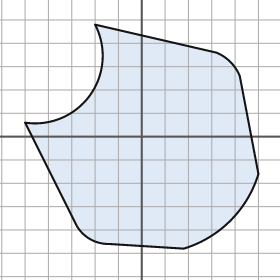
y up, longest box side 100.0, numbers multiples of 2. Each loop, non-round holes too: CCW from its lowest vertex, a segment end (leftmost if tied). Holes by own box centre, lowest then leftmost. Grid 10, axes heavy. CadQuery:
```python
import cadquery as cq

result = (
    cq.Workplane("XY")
    .moveTo(18.0, -48.0)
    .threePointArc((38.0, -36.0), (50.0, -16.0))
    .lineTo(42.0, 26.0)
    .threePointArc((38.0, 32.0), (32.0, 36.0))
    .lineTo(-20.0, 48.0)
    .threePointArc((-22.0, 18.0), (-50.0, 6.0))
    .lineTo(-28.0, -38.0)
    .threePointArc((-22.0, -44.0), (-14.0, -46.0))
    .close()
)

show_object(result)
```